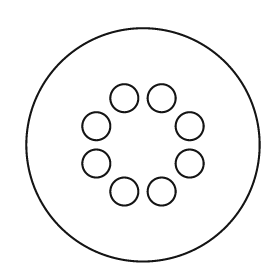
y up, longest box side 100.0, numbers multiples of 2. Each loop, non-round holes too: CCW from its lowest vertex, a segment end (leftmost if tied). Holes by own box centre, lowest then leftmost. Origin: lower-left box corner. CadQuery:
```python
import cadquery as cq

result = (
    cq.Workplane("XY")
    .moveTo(50.0, 50.0)
    .circle(50.0)
    .moveTo(42.0, 30.0)
    .circle(6.0)
    .moveTo(58.0, 30.0)
    .circle(6.0)
    .moveTo(30.0, 42.0)
    .circle(6.0)
    .moveTo(70.0, 42.0)
    .circle(6.0)
    .moveTo(30.0, 58.0)
    .circle(6.0)
    .moveTo(70.0, 58.0)
    .circle(6.0)
    .moveTo(42.0, 70.0)
    .circle(6.0)
    .moveTo(58.0, 70.0)
    .circle(6.0)
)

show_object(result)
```